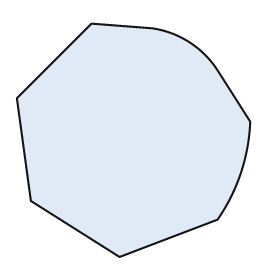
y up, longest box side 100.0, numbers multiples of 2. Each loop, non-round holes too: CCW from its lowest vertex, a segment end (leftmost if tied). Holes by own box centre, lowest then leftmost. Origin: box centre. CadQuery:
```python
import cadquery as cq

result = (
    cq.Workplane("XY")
    .moveTo(-6.0, -50.0)
    .lineTo(36.0, -34.0)
    .threePointArc((46.0, -14.0), (50.0, 8.0))
    .lineTo(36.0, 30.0)
    .threePointArc((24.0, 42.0), (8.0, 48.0))
    .lineTo(-18.0, 50.0)
    .lineTo(-50.0, 18.0)
    .lineTo(-44.0, -26.0)
    .close()
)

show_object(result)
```